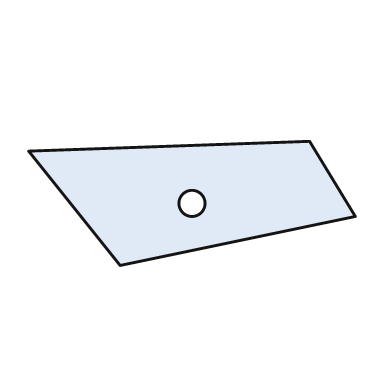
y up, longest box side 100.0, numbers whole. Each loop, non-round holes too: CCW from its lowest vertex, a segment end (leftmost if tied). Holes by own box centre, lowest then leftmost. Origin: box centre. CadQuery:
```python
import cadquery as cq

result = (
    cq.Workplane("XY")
    .moveTo(-22.0, -19.0)
    .lineTo(50.0, -4.0)
    .lineTo(36.0, 19.0)
    .lineTo(-50.0, 16.0)
    .close()
    .moveTo(0.0, 0.0)
    .circle(4.0)
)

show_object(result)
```